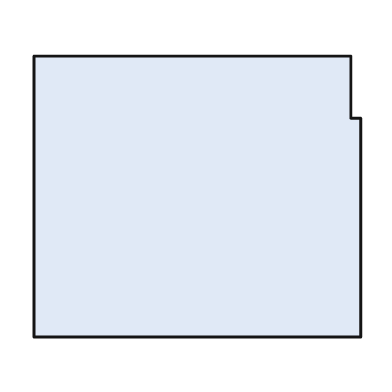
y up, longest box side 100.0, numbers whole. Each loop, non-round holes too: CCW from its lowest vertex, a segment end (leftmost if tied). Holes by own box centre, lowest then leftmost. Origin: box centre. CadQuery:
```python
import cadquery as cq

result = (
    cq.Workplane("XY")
    .moveTo(-50.0, -43.0)
    .lineTo(50.0, -43.0)
    .lineTo(50.0, 24.0)
    .lineTo(47.0, 24.0)
    .lineTo(47.0, 43.0)
    .lineTo(-50.0, 43.0)
    .close()
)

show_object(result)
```